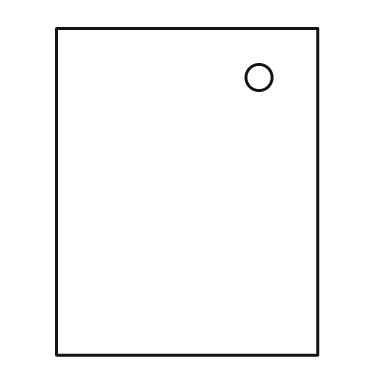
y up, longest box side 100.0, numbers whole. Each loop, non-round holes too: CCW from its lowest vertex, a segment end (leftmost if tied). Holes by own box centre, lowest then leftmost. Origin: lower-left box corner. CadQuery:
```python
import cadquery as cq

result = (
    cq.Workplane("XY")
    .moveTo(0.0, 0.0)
    .lineTo(80.0, 0.0)
    .lineTo(80.0, 100.0)
    .lineTo(0.0, 100.0)
    .close()
    .moveTo(62.0, 85.0)
    .circle(4.0)
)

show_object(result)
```